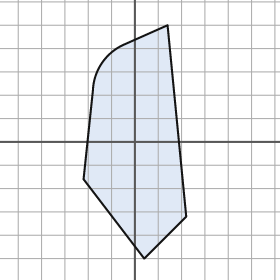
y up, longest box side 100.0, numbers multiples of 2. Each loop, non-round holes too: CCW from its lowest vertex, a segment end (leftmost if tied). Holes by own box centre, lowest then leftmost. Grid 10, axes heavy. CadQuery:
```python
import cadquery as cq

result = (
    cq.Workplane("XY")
    .moveTo(4.0, -50.0)
    .lineTo(22.0, -32.0)
    .lineTo(14.0, 50.0)
    .lineTo(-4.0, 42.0)
    .threePointArc((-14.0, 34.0), (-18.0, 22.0))
    .lineTo(-22.0, -16.0)
    .close()
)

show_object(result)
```